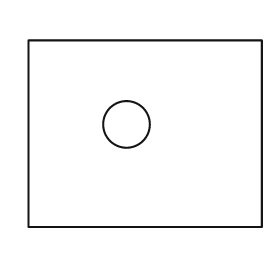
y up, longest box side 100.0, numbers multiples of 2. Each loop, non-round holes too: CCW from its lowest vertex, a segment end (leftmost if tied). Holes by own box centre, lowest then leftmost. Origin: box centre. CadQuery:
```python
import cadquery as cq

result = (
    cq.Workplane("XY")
    .moveTo(-50.0, -40.0)
    .lineTo(50.0, -40.0)
    .lineTo(50.0, 40.0)
    .lineTo(-50.0, 40.0)
    .close()
    .moveTo(-8.0, 4.0)
    .circle(10.0)
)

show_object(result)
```